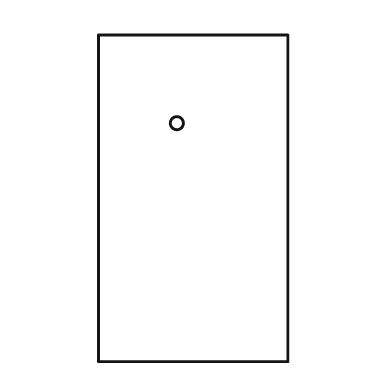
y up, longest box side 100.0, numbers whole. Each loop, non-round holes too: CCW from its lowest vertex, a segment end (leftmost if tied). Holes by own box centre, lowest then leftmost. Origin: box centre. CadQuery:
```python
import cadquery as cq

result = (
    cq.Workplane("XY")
    .moveTo(-29.0, -50.0)
    .lineTo(29.0, -50.0)
    .lineTo(29.0, 50.0)
    .lineTo(-29.0, 50.0)
    .close()
    .moveTo(-5.0, 23.0)
    .circle(2.0)
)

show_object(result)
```